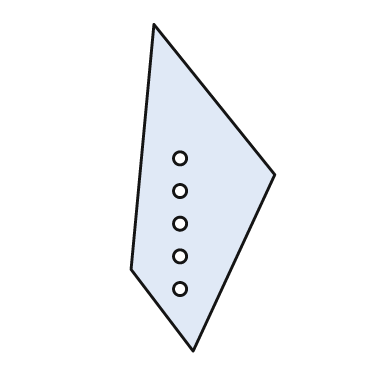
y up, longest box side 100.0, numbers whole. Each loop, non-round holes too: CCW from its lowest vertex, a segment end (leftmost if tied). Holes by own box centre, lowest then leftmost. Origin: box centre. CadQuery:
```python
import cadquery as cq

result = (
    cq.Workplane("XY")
    .moveTo(-3.0, -50.0)
    .lineTo(22.0, 4.0)
    .lineTo(-15.0, 50.0)
    .lineTo(-22.0, -25.0)
    .close()
    .moveTo(-7.0, -31.0)
    .circle(2.0)
    .moveTo(-7.0, -21.0)
    .circle(2.0)
    .moveTo(-7.0, -11.0)
    .circle(2.0)
    .moveTo(-7.0, -1.0)
    .circle(2.0)
    .moveTo(-7.0, 9.0)
    .circle(2.0)
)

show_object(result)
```